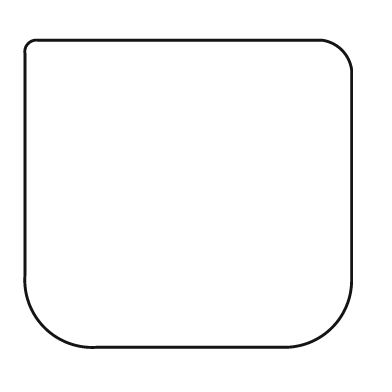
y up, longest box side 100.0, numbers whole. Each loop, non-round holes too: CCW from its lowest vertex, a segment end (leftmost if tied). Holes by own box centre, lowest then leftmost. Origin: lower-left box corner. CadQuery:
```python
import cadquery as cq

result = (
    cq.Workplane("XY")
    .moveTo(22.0, 0.0)
    .lineTo(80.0, 0.0)
    .threePointArc((94.0, 6.0), (100.0, 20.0))
    .lineTo(100.0, 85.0)
    .threePointArc((97.0, 91.0), (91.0, 94.0))
    .lineTo(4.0, 94.0)
    .threePointArc((1.0, 93.0), (0.0, 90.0))
    .lineTo(0.0, 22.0)
    .threePointArc((6.0, 6.0), (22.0, 0.0))
    .close()
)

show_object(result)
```